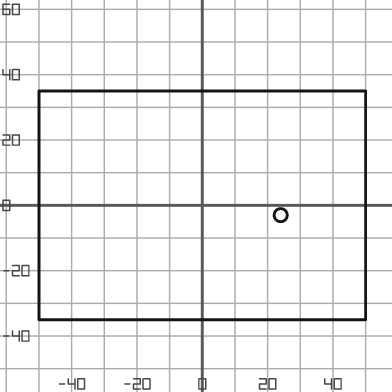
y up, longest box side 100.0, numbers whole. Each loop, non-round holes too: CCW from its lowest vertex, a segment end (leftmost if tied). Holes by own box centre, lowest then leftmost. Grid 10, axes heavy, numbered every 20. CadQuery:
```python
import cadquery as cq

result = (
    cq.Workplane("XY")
    .moveTo(-50.0, -35.0)
    .lineTo(50.0, -35.0)
    .lineTo(50.0, 35.0)
    .lineTo(-50.0, 35.0)
    .close()
    .moveTo(24.0, -3.0)
    .circle(2.0)
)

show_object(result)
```